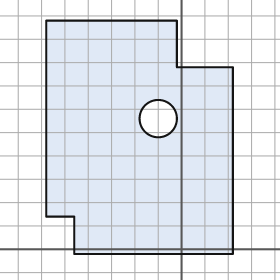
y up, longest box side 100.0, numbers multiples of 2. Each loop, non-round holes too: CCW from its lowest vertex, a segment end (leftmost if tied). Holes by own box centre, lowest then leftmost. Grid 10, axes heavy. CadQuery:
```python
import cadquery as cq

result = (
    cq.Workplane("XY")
    .moveTo(-46.0, -2.0)
    .lineTo(22.0, -2.0)
    .lineTo(22.0, 78.0)
    .lineTo(-2.0, 78.0)
    .lineTo(-2.0, 98.0)
    .lineTo(-58.0, 98.0)
    .lineTo(-58.0, 14.0)
    .lineTo(-46.0, 14.0)
    .close()
    .moveTo(-10.0, 56.0)
    .circle(8.0)
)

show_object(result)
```